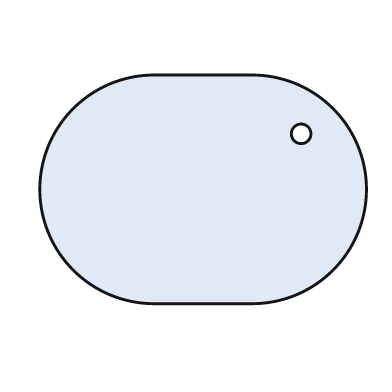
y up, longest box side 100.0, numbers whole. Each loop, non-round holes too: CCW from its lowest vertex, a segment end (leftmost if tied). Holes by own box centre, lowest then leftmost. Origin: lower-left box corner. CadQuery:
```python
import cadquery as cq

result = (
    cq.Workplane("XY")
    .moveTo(35.0, 0.0)
    .lineTo(65.0, 0.0)
    .threePointArc((100.0, 35.0), (65.0, 70.0))
    .lineTo(35.0, 70.0)
    .threePointArc((0.0, 35.0), (35.0, 0.0))
    .close()
    .moveTo(80.0, 52.0)
    .circle(3.0)
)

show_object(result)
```